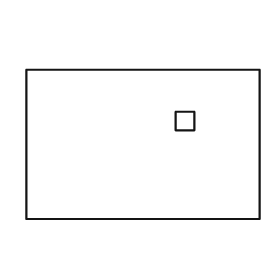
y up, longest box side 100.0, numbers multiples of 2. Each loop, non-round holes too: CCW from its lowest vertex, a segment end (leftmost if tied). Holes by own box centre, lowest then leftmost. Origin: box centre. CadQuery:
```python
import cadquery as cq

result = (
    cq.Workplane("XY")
    .moveTo(-50.0, -32.0)
    .lineTo(50.0, -32.0)
    .lineTo(50.0, 32.0)
    .lineTo(-50.0, 32.0)
    .close()
    .moveTo(14.0, 6.0)
    .lineTo(22.0, 6.0)
    .lineTo(22.0, 14.0)
    .lineTo(14.0, 14.0)
    .close()
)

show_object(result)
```